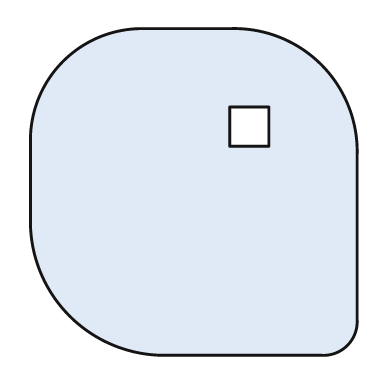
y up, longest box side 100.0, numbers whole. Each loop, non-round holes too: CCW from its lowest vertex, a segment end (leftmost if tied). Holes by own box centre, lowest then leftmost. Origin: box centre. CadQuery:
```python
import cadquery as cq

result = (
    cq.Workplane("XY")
    .moveTo(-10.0, -50.0)
    .lineTo(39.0, -50.0)
    .threePointArc((47.0, -47.0), (50.0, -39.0))
    .lineTo(50.0, 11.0)
    .threePointArc((39.0, 39.0), (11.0, 50.0))
    .lineTo(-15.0, 50.0)
    .threePointArc((-40.0, 40.0), (-50.0, 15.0))
    .lineTo(-50.0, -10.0)
    .threePointArc((-38.0, -38.0), (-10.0, -50.0))
    .close()
    .moveTo(11.0, 14.0)
    .lineTo(23.0, 14.0)
    .lineTo(23.0, 26.0)
    .lineTo(11.0, 26.0)
    .close()
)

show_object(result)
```